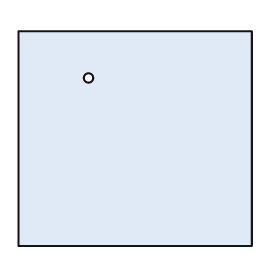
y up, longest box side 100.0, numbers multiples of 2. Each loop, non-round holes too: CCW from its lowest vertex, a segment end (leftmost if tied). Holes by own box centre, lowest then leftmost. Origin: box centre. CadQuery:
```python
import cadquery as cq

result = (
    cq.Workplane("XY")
    .moveTo(-50.0, -46.0)
    .lineTo(50.0, -46.0)
    .lineTo(50.0, 46.0)
    .lineTo(-50.0, 46.0)
    .close()
    .moveTo(-20.0, 26.0)
    .circle(2.0)
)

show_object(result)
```